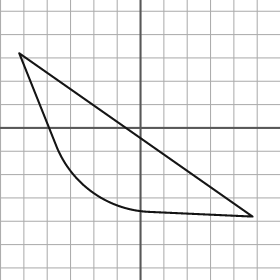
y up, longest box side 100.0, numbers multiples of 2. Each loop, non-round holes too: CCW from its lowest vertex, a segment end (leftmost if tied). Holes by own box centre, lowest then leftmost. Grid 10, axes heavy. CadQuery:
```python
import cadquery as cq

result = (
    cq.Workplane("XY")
    .moveTo(48.0, -38.0)
    .lineTo(-52.0, 32.0)
    .lineTo(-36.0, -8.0)
    .threePointArc((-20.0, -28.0), (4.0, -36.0))
    .close()
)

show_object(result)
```